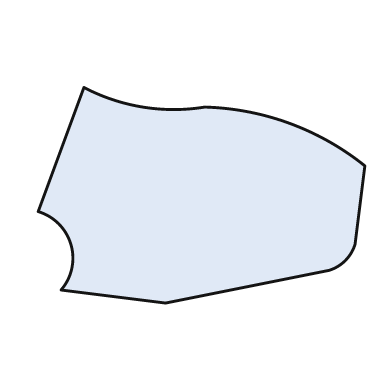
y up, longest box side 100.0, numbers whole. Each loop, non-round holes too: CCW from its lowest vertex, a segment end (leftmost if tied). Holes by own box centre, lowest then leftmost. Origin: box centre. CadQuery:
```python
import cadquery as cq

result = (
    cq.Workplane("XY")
    .moveTo(-11.0, -33.0)
    .lineTo(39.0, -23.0)
    .threePointArc((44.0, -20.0), (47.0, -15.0))
    .lineTo(50.0, 9.0)
    .threePointArc((27.0, 22.0), (1.0, 27.0))
    .threePointArc((-18.0, 27.0), (-36.0, 33.0))
    .lineTo(-50.0, -5.0)
    .threePointArc((-40.0, -15.0), (-43.0, -29.0))
    .close()
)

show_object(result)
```